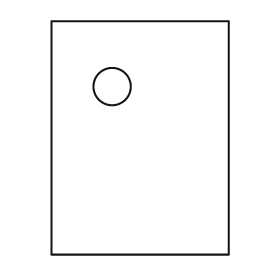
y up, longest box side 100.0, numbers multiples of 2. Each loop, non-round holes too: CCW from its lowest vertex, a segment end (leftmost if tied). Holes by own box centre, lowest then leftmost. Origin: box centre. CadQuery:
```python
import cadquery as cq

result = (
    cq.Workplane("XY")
    .moveTo(-38.0, -50.0)
    .lineTo(38.0, -50.0)
    .lineTo(38.0, 50.0)
    .lineTo(-38.0, 50.0)
    .close()
    .moveTo(-12.0, 22.0)
    .circle(8.0)
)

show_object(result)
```